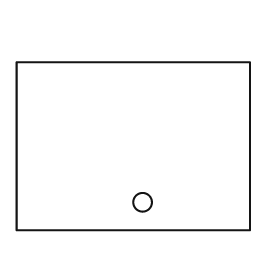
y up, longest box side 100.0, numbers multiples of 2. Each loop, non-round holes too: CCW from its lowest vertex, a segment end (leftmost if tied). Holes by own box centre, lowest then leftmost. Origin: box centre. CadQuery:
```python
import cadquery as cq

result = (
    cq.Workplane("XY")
    .moveTo(-50.0, -36.0)
    .lineTo(50.0, -36.0)
    .lineTo(50.0, 36.0)
    .lineTo(-50.0, 36.0)
    .close()
    .moveTo(4.0, -24.0)
    .circle(4.0)
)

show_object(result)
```